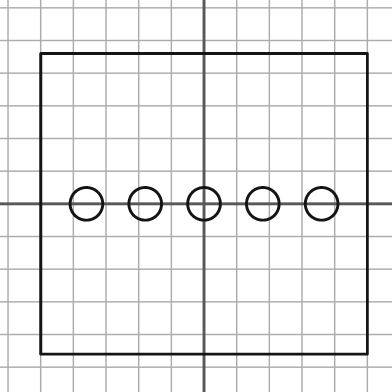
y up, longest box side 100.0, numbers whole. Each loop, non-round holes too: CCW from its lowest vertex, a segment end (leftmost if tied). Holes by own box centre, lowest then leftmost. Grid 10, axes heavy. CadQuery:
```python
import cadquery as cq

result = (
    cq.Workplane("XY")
    .moveTo(-50.0, -46.0)
    .lineTo(50.0, -46.0)
    .lineTo(50.0, 46.0)
    .lineTo(-50.0, 46.0)
    .close()
    .moveTo(-36.0, 0.0)
    .circle(5.0)
    .moveTo(-18.0, 0.0)
    .circle(5.0)
    .moveTo(0.0, 0.0)
    .circle(5.0)
    .moveTo(18.0, 0.0)
    .circle(5.0)
    .moveTo(36.0, 0.0)
    .circle(5.0)
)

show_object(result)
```